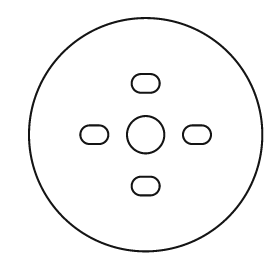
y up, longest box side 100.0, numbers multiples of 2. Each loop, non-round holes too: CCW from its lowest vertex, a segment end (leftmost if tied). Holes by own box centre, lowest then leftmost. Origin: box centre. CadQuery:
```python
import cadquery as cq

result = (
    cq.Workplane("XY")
    .moveTo(0.0, 0.0)
    .circle(50.0)
    .moveTo(-2.0, -26.0)
    .lineTo(2.0, -26.0)
    .threePointArc((6.0, -22.0), (2.0, -18.0))
    .lineTo(-2.0, -18.0)
    .threePointArc((-6.0, -22.0), (-2.0, -26.0))
    .close()
    .moveTo(-24.0, -4.0)
    .lineTo(-20.0, -4.0)
    .threePointArc((-16.0, 0.0), (-20.0, 4.0))
    .lineTo(-24.0, 4.0)
    .threePointArc((-28.0, 0.0), (-24.0, -4.0))
    .close()
    .moveTo(0.0, 0.0)
    .circle(8.0)
    .moveTo(20.0, -4.0)
    .lineTo(24.0, -4.0)
    .threePointArc((28.0, 0.0), (24.0, 4.0))
    .lineTo(20.0, 4.0)
    .threePointArc((16.0, 0.0), (20.0, -4.0))
    .close()
    .moveTo(-2.0, 18.0)
    .lineTo(2.0, 18.0)
    .threePointArc((6.0, 22.0), (2.0, 26.0))
    .lineTo(-2.0, 26.0)
    .threePointArc((-6.0, 22.0), (-2.0, 18.0))
    .close()
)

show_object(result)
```